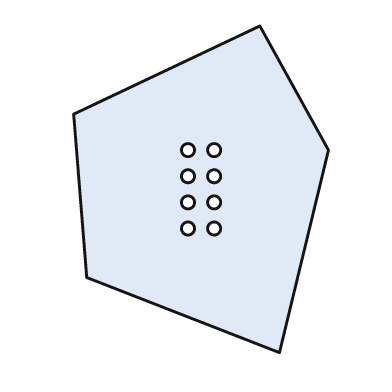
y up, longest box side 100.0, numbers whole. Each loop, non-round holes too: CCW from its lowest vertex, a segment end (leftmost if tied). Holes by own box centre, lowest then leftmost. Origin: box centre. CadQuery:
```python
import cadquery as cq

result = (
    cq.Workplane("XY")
    .moveTo(24.0, -50.0)
    .lineTo(39.0, 12.0)
    .lineTo(18.0, 50.0)
    .lineTo(-39.0, 23.0)
    .lineTo(-35.0, -27.0)
    .close()
    .moveTo(-4.0, -12.0)
    .circle(2.0)
    .moveTo(4.0, -12.0)
    .circle(2.0)
    .moveTo(-4.0, -4.0)
    .circle(2.0)
    .moveTo(4.0, -4.0)
    .circle(2.0)
    .moveTo(-4.0, 4.0)
    .circle(2.0)
    .moveTo(4.0, 4.0)
    .circle(2.0)
    .moveTo(-4.0, 12.0)
    .circle(2.0)
    .moveTo(4.0, 12.0)
    .circle(2.0)
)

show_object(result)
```